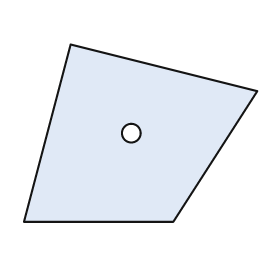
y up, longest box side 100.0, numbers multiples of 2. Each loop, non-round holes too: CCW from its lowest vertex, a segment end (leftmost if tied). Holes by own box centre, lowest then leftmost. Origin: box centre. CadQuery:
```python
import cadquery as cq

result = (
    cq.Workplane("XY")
    .moveTo(-50.0, -38.0)
    .lineTo(14.0, -38.0)
    .lineTo(50.0, 18.0)
    .lineTo(-30.0, 38.0)
    .close()
    .moveTo(-4.0, 0.0)
    .circle(4.0)
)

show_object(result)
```